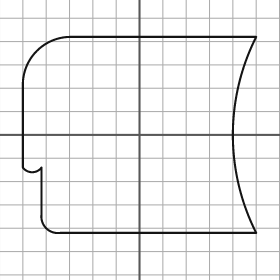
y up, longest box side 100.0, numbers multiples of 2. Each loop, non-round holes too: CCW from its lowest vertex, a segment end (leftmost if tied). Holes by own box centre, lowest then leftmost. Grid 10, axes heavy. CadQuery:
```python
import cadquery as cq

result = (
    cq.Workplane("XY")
    .moveTo(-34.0, -42.0)
    .lineTo(50.0, -42.0)
    .threePointArc((40.0, 0.0), (50.0, 42.0))
    .lineTo(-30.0, 42.0)
    .threePointArc((-44.0, 36.0), (-50.0, 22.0))
    .lineTo(-50.0, -14.0)
    .threePointArc((-46.0, -16.0), (-42.0, -14.0))
    .lineTo(-42.0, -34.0)
    .threePointArc((-40.0, -40.0), (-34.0, -42.0))
    .close()
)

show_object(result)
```